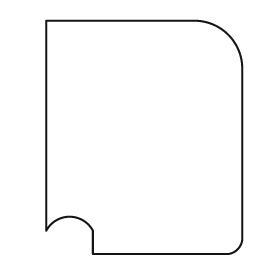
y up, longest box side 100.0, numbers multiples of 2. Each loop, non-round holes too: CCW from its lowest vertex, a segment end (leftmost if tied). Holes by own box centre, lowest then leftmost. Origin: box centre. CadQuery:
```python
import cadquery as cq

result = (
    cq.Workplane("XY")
    .moveTo(-22.0, -50.0)
    .lineTo(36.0, -50.0)
    .threePointArc((40.0, -48.0), (42.0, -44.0))
    .lineTo(42.0, 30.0)
    .threePointArc((36.0, 44.0), (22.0, 50.0))
    .lineTo(-42.0, 50.0)
    .lineTo(-42.0, -40.0)
    .threePointArc((-32.0, -34.0), (-22.0, -40.0))
    .close()
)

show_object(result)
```